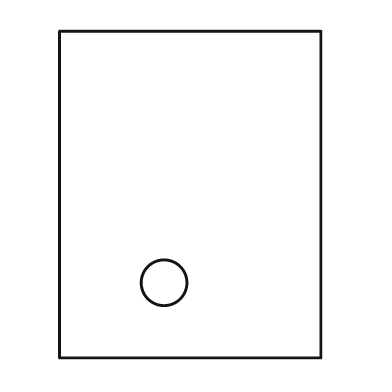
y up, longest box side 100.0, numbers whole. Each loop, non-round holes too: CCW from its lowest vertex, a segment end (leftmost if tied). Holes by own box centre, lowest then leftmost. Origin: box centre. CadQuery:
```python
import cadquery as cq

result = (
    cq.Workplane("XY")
    .moveTo(-40.0, -50.0)
    .lineTo(40.0, -50.0)
    .lineTo(40.0, 50.0)
    .lineTo(-40.0, 50.0)
    .close()
    .moveTo(-8.0, -27.0)
    .circle(7.0)
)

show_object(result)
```